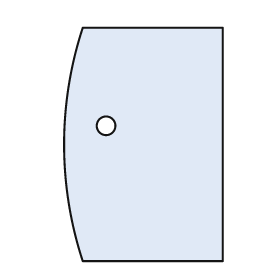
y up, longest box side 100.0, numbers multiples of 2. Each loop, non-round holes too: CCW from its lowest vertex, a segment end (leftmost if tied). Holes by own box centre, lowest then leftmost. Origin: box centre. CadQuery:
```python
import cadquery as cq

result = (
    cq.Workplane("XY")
    .moveTo(-26.0, -50.0)
    .lineTo(34.0, -50.0)
    .lineTo(34.0, 50.0)
    .lineTo(-26.0, 50.0)
    .threePointArc((-34.0, 0.0), (-26.0, -50.0))
    .close()
    .moveTo(-16.0, 8.0)
    .circle(4.0)
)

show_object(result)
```